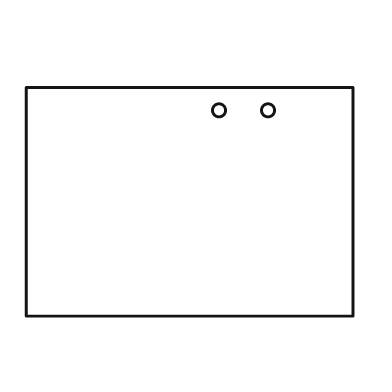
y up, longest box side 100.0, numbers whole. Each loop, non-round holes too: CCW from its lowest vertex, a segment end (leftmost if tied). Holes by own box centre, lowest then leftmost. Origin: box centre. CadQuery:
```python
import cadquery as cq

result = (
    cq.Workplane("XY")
    .moveTo(-50.0, -35.0)
    .lineTo(50.0, -35.0)
    .lineTo(50.0, 35.0)
    .lineTo(-50.0, 35.0)
    .close()
    .moveTo(9.0, 28.0)
    .circle(2.0)
    .moveTo(24.0, 28.0)
    .circle(2.0)
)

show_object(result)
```